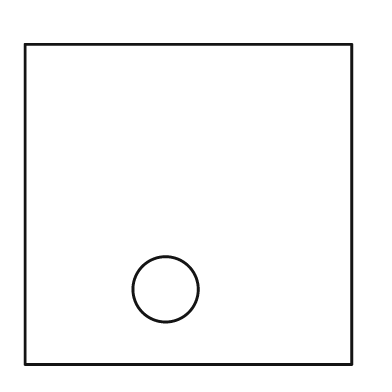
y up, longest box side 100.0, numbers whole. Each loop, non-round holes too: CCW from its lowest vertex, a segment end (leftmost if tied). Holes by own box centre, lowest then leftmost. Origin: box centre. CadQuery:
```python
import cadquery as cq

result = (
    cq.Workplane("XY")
    .moveTo(-50.0, -49.0)
    .lineTo(50.0, -49.0)
    .lineTo(50.0, 49.0)
    .lineTo(-50.0, 49.0)
    .close()
    .moveTo(-7.0, -26.0)
    .circle(10.0)
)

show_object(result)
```